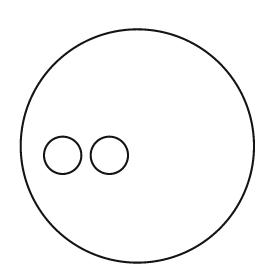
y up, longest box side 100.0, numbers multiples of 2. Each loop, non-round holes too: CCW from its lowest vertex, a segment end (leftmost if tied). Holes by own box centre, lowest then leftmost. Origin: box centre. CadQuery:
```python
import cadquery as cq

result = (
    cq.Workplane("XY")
    .moveTo(0.0, 0.0)
    .circle(50.0)
    .moveTo(-32.0, -4.0)
    .circle(8.0)
    .moveTo(-12.0, -4.0)
    .circle(8.0)
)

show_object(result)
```